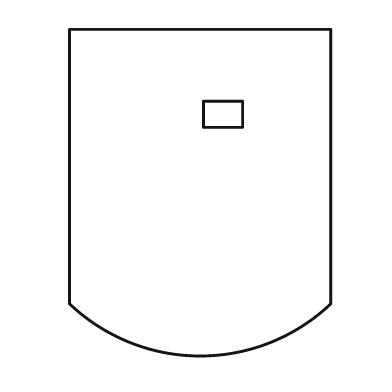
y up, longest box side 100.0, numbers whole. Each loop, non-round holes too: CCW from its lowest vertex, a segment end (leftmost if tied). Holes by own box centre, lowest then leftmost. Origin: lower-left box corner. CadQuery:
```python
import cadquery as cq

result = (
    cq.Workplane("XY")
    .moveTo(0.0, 16.0)
    .threePointArc((40.0, 0.0), (80.0, 16.0))
    .lineTo(80.0, 100.0)
    .lineTo(0.0, 100.0)
    .close()
    .moveTo(41.0, 70.0)
    .lineTo(53.0, 70.0)
    .lineTo(53.0, 78.0)
    .lineTo(41.0, 78.0)
    .close()
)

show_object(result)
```